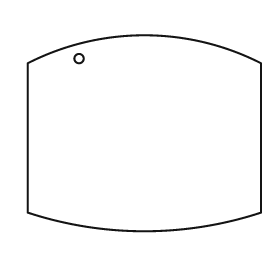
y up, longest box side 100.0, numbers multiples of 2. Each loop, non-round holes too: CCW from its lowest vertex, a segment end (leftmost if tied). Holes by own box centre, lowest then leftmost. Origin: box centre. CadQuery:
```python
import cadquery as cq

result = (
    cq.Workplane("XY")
    .moveTo(-50.0, -34.0)
    .threePointArc((0.0, -42.0), (50.0, -34.0))
    .lineTo(50.0, 30.0)
    .threePointArc((0.0, 42.0), (-50.0, 30.0))
    .close()
    .moveTo(-28.0, 32.0)
    .circle(2.0)
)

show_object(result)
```